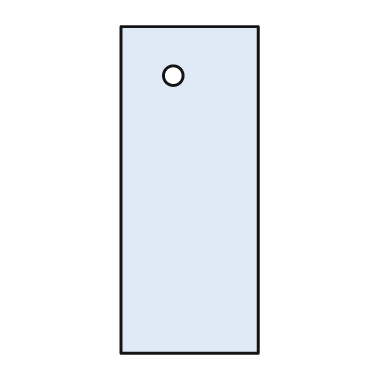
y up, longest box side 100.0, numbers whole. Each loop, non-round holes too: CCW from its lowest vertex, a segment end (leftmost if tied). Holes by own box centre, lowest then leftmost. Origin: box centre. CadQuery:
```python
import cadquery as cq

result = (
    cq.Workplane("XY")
    .moveTo(-21.0, -50.0)
    .lineTo(21.0, -50.0)
    .lineTo(21.0, 50.0)
    .lineTo(-21.0, 50.0)
    .close()
    .moveTo(-5.0, 35.0)
    .circle(3.0)
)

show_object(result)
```